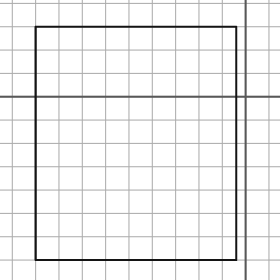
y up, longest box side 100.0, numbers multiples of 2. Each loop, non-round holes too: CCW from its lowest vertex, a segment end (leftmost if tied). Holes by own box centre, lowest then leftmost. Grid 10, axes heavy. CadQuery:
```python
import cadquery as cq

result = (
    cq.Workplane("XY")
    .moveTo(-90.0, -70.0)
    .lineTo(-4.0, -70.0)
    .lineTo(-4.0, 30.0)
    .lineTo(-90.0, 30.0)
    .close()
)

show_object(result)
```